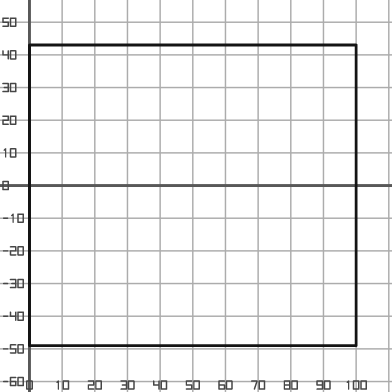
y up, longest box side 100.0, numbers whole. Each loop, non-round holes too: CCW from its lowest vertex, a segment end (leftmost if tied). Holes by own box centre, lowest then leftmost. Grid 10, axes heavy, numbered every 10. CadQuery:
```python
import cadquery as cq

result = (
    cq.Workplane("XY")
    .moveTo(0.0, -49.0)
    .lineTo(100.0, -49.0)
    .lineTo(100.0, 43.0)
    .lineTo(0.0, 43.0)
    .close()
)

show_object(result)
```